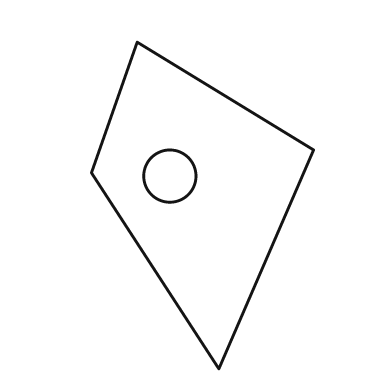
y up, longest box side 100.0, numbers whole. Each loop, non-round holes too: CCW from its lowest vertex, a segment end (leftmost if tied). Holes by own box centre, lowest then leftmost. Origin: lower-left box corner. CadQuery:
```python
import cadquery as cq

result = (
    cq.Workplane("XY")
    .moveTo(39.0, 0.0)
    .lineTo(68.0, 67.0)
    .lineTo(14.0, 100.0)
    .lineTo(0.0, 60.0)
    .close()
    .moveTo(24.0, 59.0)
    .circle(8.0)
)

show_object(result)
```